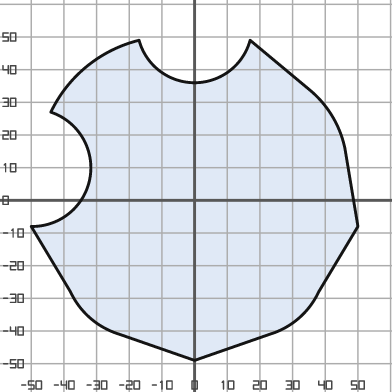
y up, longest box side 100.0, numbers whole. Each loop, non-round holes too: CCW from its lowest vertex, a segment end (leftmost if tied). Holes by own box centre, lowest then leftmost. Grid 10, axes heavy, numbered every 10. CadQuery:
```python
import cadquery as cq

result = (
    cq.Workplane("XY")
    .moveTo(0.0, -49.0)
    .lineTo(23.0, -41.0)
    .threePointArc((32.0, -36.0), (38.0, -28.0))
    .lineTo(50.0, -8.0)
    .lineTo(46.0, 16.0)
    .threePointArc((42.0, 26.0), (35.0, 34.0))
    .lineTo(17.0, 49.0)
    .threePointArc((0.0, 36.0), (-17.0, 49.0))
    .threePointArc((-33.0, 41.0), (-44.0, 27.0))
    .threePointArc((-32.0, 7.0), (-50.0, -8.0))
    .lineTo(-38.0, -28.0)
    .threePointArc((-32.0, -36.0), (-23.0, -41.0))
    .close()
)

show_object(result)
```